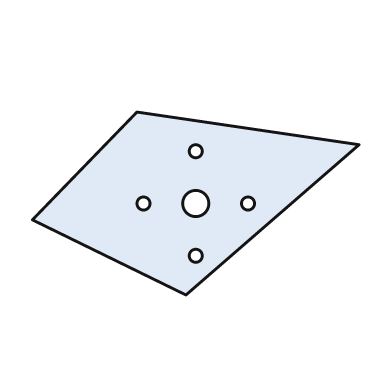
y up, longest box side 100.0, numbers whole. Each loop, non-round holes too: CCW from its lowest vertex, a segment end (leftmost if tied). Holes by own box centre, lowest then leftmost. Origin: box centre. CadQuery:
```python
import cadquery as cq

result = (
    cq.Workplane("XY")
    .moveTo(-3.0, -28.0)
    .lineTo(50.0, 18.0)
    .lineTo(-18.0, 28.0)
    .lineTo(-50.0, -5.0)
    .close()
    .moveTo(0.0, -16.0)
    .circle(2.0)
    .moveTo(-16.0, 0.0)
    .circle(2.0)
    .moveTo(0.0, 0.0)
    .circle(4.0)
    .moveTo(16.0, 0.0)
    .circle(2.0)
    .moveTo(0.0, 16.0)
    .circle(2.0)
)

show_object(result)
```